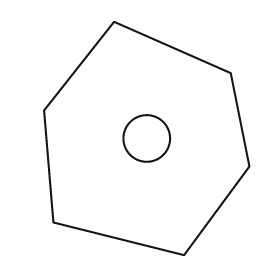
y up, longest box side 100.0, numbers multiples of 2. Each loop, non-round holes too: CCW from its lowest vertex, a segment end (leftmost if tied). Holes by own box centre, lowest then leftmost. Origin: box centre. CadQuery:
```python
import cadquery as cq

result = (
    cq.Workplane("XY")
    .moveTo(16.0, -50.0)
    .lineTo(44.0, -12.0)
    .lineTo(36.0, 28.0)
    .lineTo(-14.0, 50.0)
    .lineTo(-44.0, 12.0)
    .lineTo(-40.0, -36.0)
    .close()
    .moveTo(0.0, 0.0)
    .circle(10.0)
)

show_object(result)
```